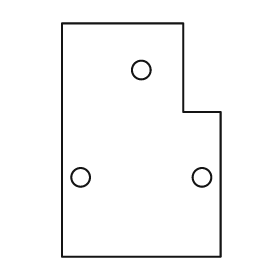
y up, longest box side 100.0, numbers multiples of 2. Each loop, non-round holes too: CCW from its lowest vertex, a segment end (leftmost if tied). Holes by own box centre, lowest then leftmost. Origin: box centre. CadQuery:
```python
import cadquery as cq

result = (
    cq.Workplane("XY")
    .moveTo(-34.0, -50.0)
    .lineTo(34.0, -50.0)
    .lineTo(34.0, 12.0)
    .lineTo(18.0, 12.0)
    .lineTo(18.0, 50.0)
    .lineTo(-34.0, 50.0)
    .close()
    .moveTo(-26.0, -16.0)
    .circle(4.0)
    .moveTo(26.0, -16.0)
    .circle(4.0)
    .moveTo(0.0, 30.0)
    .circle(4.0)
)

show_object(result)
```